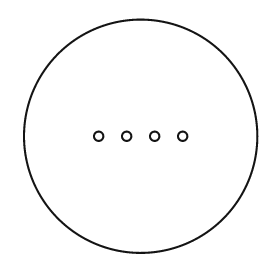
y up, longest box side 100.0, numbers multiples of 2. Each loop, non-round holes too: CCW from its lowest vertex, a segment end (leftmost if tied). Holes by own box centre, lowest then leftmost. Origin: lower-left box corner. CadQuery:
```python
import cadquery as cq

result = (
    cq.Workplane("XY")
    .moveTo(50.0, 50.0)
    .circle(50.0)
    .moveTo(32.0, 50.0)
    .circle(2.0)
    .moveTo(44.0, 50.0)
    .circle(2.0)
    .moveTo(56.0, 50.0)
    .circle(2.0)
    .moveTo(68.0, 50.0)
    .circle(2.0)
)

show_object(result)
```